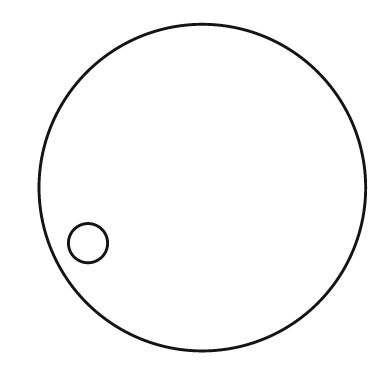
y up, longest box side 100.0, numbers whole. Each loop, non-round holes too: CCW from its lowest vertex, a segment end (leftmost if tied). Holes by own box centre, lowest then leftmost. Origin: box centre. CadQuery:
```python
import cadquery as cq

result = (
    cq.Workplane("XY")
    .moveTo(0.0, 0.0)
    .circle(50.0)
    .moveTo(-35.0, -17.0)
    .circle(6.0)
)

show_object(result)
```